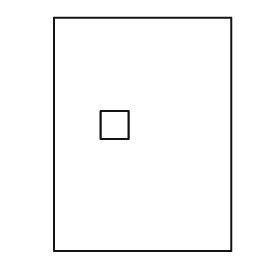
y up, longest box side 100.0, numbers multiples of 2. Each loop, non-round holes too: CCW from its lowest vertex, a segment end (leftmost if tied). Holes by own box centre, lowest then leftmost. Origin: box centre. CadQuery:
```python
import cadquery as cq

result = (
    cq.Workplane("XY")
    .moveTo(-38.0, -50.0)
    .lineTo(38.0, -50.0)
    .lineTo(38.0, 50.0)
    .lineTo(-38.0, 50.0)
    .close()
    .moveTo(-18.0, -2.0)
    .lineTo(-6.0, -2.0)
    .lineTo(-6.0, 10.0)
    .lineTo(-18.0, 10.0)
    .close()
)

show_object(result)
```